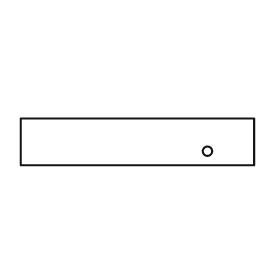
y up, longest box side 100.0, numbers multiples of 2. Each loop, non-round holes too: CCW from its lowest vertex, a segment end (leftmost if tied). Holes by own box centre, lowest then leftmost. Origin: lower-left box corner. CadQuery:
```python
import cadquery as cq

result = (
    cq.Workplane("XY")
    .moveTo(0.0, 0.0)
    .lineTo(100.0, 0.0)
    .lineTo(100.0, 20.0)
    .lineTo(0.0, 20.0)
    .close()
    .moveTo(80.0, 6.0)
    .circle(2.0)
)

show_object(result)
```